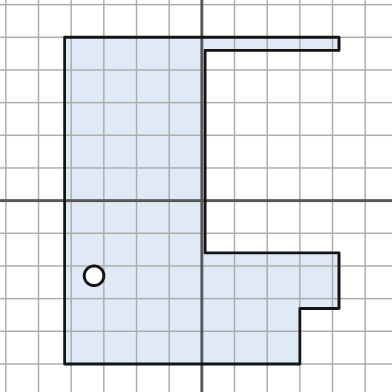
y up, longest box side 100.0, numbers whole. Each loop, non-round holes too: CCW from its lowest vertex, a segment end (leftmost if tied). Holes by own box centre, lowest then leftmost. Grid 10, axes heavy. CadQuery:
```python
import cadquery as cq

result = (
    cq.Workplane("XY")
    .moveTo(-42.0, -50.0)
    .lineTo(30.0, -50.0)
    .lineTo(30.0, -33.0)
    .lineTo(42.0, -33.0)
    .lineTo(42.0, -16.0)
    .lineTo(1.0, -16.0)
    .lineTo(1.0, 46.0)
    .lineTo(42.0, 46.0)
    .lineTo(42.0, 50.0)
    .lineTo(-42.0, 50.0)
    .close()
    .moveTo(-33.0, -23.0)
    .circle(3.0)
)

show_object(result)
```